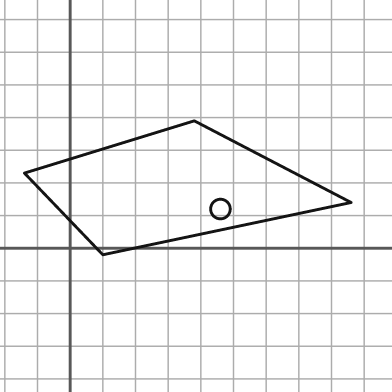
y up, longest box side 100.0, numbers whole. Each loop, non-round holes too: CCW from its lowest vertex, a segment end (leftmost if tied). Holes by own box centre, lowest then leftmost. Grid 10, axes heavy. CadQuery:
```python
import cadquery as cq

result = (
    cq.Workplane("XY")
    .moveTo(10.0, -2.0)
    .lineTo(86.0, 14.0)
    .lineTo(38.0, 39.0)
    .lineTo(-14.0, 23.0)
    .close()
    .moveTo(46.0, 12.0)
    .circle(3.0)
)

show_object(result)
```